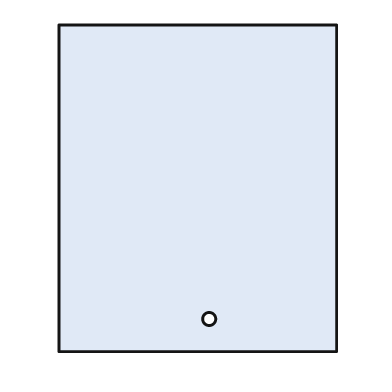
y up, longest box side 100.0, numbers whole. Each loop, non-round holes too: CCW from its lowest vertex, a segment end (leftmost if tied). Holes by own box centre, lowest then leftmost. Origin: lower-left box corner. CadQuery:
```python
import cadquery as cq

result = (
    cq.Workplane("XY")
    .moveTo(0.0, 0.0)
    .lineTo(85.0, 0.0)
    .lineTo(85.0, 100.0)
    .lineTo(0.0, 100.0)
    .close()
    .moveTo(46.0, 10.0)
    .circle(2.0)
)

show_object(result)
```